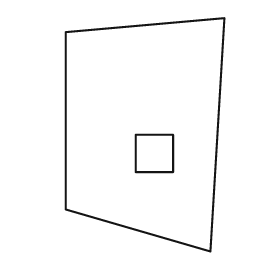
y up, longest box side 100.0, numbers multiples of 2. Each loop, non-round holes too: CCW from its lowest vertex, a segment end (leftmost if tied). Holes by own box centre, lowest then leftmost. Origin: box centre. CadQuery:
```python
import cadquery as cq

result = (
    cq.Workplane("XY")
    .moveTo(28.0, -50.0)
    .lineTo(34.0, 50.0)
    .lineTo(-34.0, 44.0)
    .lineTo(-34.0, -32.0)
    .close()
    .moveTo(-4.0, -16.0)
    .lineTo(12.0, -16.0)
    .lineTo(12.0, 0.0)
    .lineTo(-4.0, 0.0)
    .close()
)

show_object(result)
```